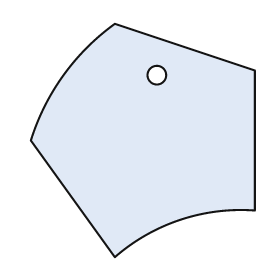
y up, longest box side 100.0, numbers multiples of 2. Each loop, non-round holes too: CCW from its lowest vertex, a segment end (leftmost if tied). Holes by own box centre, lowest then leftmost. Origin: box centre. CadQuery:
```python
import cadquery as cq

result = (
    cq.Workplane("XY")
    .moveTo(-12.0, -50.0)
    .threePointArc((16.0, -34.0), (48.0, -30.0))
    .lineTo(48.0, 30.0)
    .lineTo(-12.0, 50.0)
    .threePointArc((-34.0, 28.0), (-48.0, 0.0))
    .close()
    .moveTo(6.0, 28.0)
    .circle(4.0)
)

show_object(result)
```